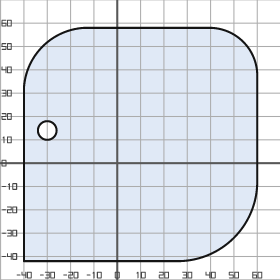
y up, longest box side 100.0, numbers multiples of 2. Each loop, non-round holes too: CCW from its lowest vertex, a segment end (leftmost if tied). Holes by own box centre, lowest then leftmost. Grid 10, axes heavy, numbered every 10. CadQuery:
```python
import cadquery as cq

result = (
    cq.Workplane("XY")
    .moveTo(-40.0, -42.0)
    .lineTo(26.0, -42.0)
    .threePointArc((50.0, -32.0), (60.0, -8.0))
    .lineTo(60.0, 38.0)
    .threePointArc((54.0, 52.0), (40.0, 58.0))
    .lineTo(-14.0, 58.0)
    .threePointArc((-32.0, 50.0), (-40.0, 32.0))
    .close()
    .moveTo(-30.0, 14.0)
    .circle(4.0)
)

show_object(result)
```